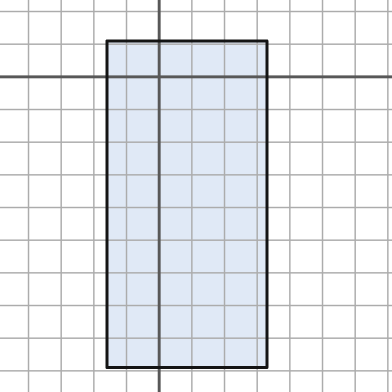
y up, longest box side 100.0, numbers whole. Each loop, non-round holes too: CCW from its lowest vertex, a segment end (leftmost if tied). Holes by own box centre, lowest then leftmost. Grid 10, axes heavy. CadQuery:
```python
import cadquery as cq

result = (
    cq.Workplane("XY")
    .moveTo(-16.0, -89.0)
    .lineTo(33.0, -89.0)
    .lineTo(33.0, 11.0)
    .lineTo(-16.0, 11.0)
    .close()
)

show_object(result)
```